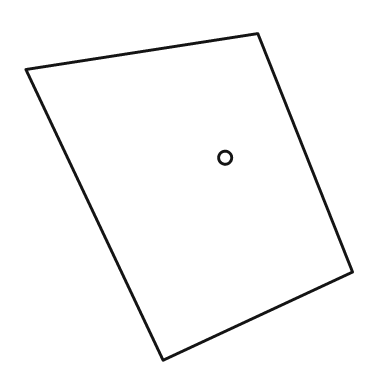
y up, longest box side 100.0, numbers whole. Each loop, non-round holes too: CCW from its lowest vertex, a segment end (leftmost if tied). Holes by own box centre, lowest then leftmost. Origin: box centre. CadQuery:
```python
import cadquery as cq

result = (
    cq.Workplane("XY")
    .moveTo(-8.0, -50.0)
    .lineTo(50.0, -23.0)
    .lineTo(21.0, 50.0)
    .lineTo(-50.0, 39.0)
    .close()
    .moveTo(11.0, 12.0)
    .circle(2.0)
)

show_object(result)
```